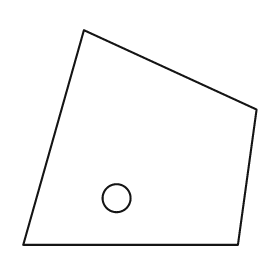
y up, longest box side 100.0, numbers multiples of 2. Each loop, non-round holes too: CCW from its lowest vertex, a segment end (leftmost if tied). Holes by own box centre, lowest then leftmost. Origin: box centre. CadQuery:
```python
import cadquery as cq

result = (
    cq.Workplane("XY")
    .moveTo(-50.0, -46.0)
    .lineTo(42.0, -46.0)
    .lineTo(50.0, 12.0)
    .lineTo(-24.0, 46.0)
    .close()
    .moveTo(-10.0, -26.0)
    .circle(6.0)
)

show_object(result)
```